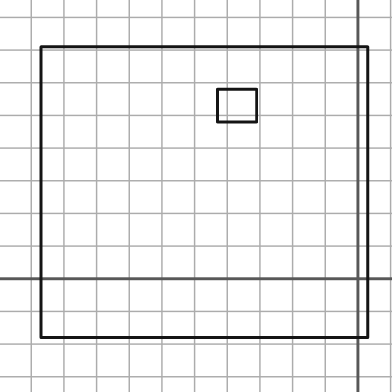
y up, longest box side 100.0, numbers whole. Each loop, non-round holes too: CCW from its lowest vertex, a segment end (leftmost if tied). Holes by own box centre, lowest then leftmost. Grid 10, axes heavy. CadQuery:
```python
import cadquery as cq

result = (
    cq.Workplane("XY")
    .moveTo(-97.0, -18.0)
    .lineTo(3.0, -18.0)
    .lineTo(3.0, 71.0)
    .lineTo(-97.0, 71.0)
    .close()
    .moveTo(-43.0, 48.0)
    .lineTo(-31.0, 48.0)
    .lineTo(-31.0, 58.0)
    .lineTo(-43.0, 58.0)
    .close()
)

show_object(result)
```